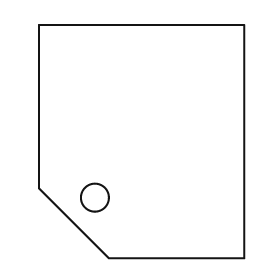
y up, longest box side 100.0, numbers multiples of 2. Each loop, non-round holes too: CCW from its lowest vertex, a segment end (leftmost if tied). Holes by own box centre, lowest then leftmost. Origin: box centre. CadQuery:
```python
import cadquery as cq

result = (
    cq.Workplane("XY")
    .moveTo(-14.0, -50.0)
    .lineTo(44.0, -50.0)
    .lineTo(44.0, 50.0)
    .lineTo(-44.0, 50.0)
    .lineTo(-44.0, -20.0)
    .close()
    .moveTo(-20.0, -24.0)
    .circle(6.0)
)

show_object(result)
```